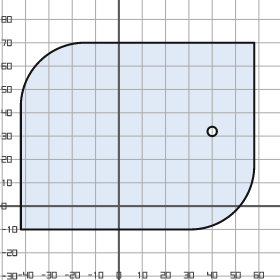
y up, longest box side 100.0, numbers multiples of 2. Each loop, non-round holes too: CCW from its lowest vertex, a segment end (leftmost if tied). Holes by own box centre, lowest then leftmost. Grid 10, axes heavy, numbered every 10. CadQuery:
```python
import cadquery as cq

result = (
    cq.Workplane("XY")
    .moveTo(-42.0, -10.0)
    .lineTo(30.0, -10.0)
    .threePointArc((50.0, -2.0), (58.0, 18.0))
    .lineTo(58.0, 70.0)
    .lineTo(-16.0, 70.0)
    .threePointArc((-34.0, 62.0), (-42.0, 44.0))
    .close()
    .moveTo(40.0, 32.0)
    .circle(2.0)
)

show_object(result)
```